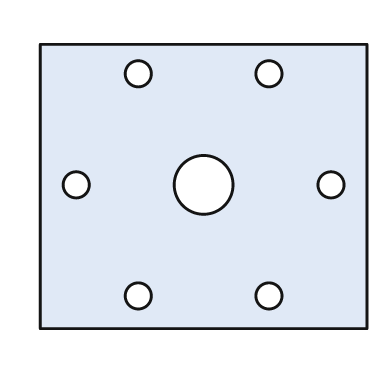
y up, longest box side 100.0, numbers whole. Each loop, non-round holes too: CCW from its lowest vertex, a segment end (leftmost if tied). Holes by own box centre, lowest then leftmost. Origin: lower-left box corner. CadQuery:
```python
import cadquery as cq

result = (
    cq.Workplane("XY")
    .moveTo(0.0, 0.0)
    .lineTo(100.0, 0.0)
    .lineTo(100.0, 87.0)
    .lineTo(0.0, 87.0)
    .close()
    .moveTo(30.0, 10.0)
    .circle(4.0)
    .moveTo(70.0, 10.0)
    .circle(4.0)
    .moveTo(11.0, 44.0)
    .circle(4.0)
    .moveTo(50.0, 44.0)
    .circle(9.0)
    .moveTo(89.0, 44.0)
    .circle(4.0)
    .moveTo(30.0, 78.0)
    .circle(4.0)
    .moveTo(70.0, 78.0)
    .circle(4.0)
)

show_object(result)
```